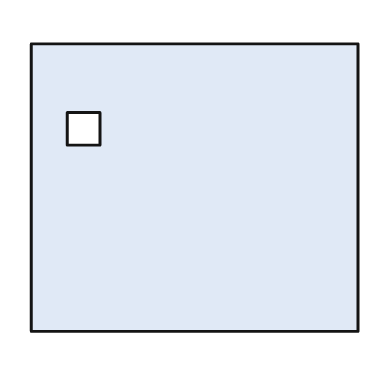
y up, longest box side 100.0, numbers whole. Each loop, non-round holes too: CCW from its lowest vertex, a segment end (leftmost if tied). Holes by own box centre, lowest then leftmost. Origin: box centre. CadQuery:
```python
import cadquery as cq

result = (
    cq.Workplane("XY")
    .moveTo(-50.0, -44.0)
    .lineTo(50.0, -44.0)
    .lineTo(50.0, 44.0)
    .lineTo(-50.0, 44.0)
    .close()
    .moveTo(-39.0, 13.0)
    .lineTo(-29.0, 13.0)
    .lineTo(-29.0, 23.0)
    .lineTo(-39.0, 23.0)
    .close()
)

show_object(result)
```